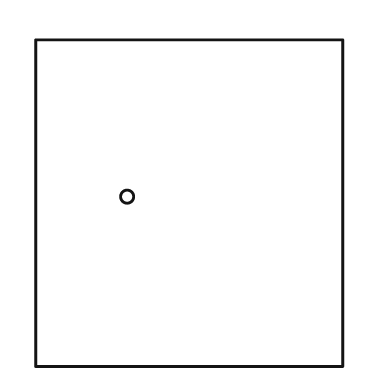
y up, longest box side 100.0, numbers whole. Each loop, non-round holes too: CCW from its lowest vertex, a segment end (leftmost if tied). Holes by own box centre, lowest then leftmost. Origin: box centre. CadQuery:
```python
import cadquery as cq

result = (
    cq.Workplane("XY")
    .moveTo(-47.0, -50.0)
    .lineTo(47.0, -50.0)
    .lineTo(47.0, 50.0)
    .lineTo(-47.0, 50.0)
    .close()
    .moveTo(-19.0, 2.0)
    .circle(2.0)
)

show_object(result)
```